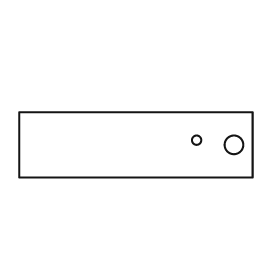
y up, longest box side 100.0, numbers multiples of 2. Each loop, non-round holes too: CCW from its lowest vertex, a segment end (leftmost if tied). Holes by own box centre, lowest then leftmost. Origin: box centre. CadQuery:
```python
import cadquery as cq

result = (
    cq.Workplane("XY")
    .moveTo(-50.0, -14.0)
    .lineTo(50.0, -14.0)
    .lineTo(50.0, 14.0)
    .lineTo(-50.0, 14.0)
    .close()
    .moveTo(42.0, 0.0)
    .circle(4.0)
    .moveTo(26.0, 2.0)
    .circle(2.0)
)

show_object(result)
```